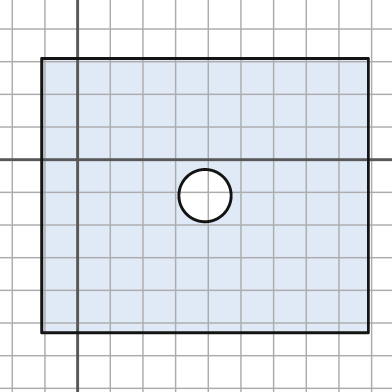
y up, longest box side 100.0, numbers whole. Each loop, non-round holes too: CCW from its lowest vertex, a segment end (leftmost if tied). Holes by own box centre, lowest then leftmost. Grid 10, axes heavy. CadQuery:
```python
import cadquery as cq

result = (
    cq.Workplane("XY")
    .moveTo(-11.0, -53.0)
    .lineTo(89.0, -53.0)
    .lineTo(89.0, 31.0)
    .lineTo(-11.0, 31.0)
    .close()
    .moveTo(39.0, -11.0)
    .circle(8.0)
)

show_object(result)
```